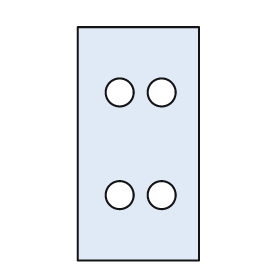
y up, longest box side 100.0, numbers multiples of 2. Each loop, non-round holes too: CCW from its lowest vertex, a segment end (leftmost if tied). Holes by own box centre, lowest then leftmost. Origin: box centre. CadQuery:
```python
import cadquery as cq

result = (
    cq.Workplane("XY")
    .moveTo(-26.0, -50.0)
    .lineTo(26.0, -50.0)
    .lineTo(26.0, 50.0)
    .lineTo(-26.0, 50.0)
    .close()
    .moveTo(-8.0, -22.0)
    .circle(6.0)
    .moveTo(10.0, -22.0)
    .circle(6.0)
    .moveTo(-8.0, 22.0)
    .circle(6.0)
    .moveTo(10.0, 22.0)
    .circle(6.0)
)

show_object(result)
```